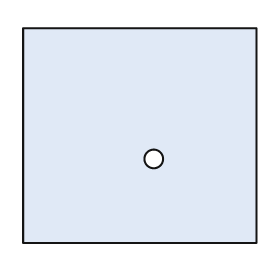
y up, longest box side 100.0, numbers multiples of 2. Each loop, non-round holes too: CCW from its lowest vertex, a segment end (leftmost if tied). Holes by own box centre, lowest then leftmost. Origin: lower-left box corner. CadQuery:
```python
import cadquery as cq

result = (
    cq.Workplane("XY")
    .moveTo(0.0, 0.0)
    .lineTo(100.0, 0.0)
    .lineTo(100.0, 92.0)
    .lineTo(0.0, 92.0)
    .close()
    .moveTo(56.0, 36.0)
    .circle(4.0)
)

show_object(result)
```